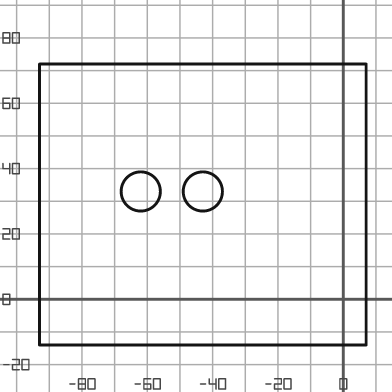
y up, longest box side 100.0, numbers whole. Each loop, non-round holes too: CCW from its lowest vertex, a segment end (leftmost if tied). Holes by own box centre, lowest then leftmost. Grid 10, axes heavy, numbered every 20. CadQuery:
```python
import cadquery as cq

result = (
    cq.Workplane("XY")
    .moveTo(-93.0, -14.0)
    .lineTo(7.0, -14.0)
    .lineTo(7.0, 72.0)
    .lineTo(-93.0, 72.0)
    .close()
    .moveTo(-62.0, 33.0)
    .circle(6.0)
    .moveTo(-43.0, 33.0)
    .circle(6.0)
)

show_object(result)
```